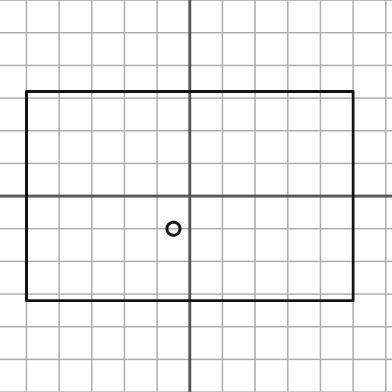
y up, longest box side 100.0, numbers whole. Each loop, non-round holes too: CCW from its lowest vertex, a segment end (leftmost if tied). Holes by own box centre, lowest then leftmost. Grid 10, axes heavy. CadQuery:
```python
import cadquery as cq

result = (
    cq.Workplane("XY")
    .moveTo(-50.0, -32.0)
    .lineTo(50.0, -32.0)
    .lineTo(50.0, 32.0)
    .lineTo(-50.0, 32.0)
    .close()
    .moveTo(-5.0, -10.0)
    .circle(2.0)
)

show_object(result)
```